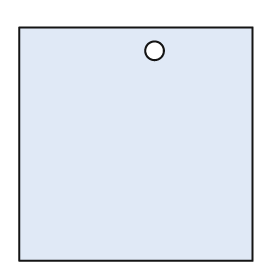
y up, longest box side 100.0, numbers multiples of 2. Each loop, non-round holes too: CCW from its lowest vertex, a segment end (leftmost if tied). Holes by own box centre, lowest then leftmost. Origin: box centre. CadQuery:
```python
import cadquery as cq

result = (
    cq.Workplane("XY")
    .moveTo(-50.0, -50.0)
    .lineTo(50.0, -50.0)
    .lineTo(50.0, 50.0)
    .lineTo(-50.0, 50.0)
    .close()
    .moveTo(8.0, 40.0)
    .circle(4.0)
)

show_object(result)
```